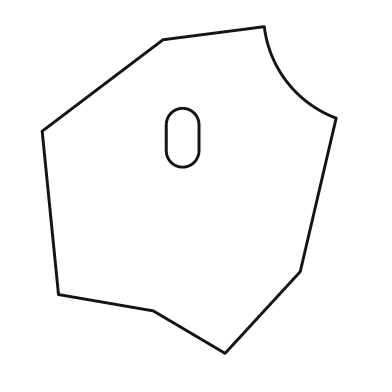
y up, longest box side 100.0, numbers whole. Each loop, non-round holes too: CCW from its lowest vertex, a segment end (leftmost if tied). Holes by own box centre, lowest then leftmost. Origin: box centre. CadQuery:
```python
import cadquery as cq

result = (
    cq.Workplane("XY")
    .moveTo(11.0, -50.0)
    .lineTo(34.0, -25.0)
    .lineTo(45.0, 22.0)
    .threePointArc((30.0, 33.0), (23.0, 50.0))
    .lineTo(-8.0, 46.0)
    .lineTo(-45.0, 18.0)
    .lineTo(-40.0, -32.0)
    .lineTo(-11.0, -37.0)
    .close()
    .moveTo(-7.0, 12.0)
    .threePointArc((-2.0, 7.0), (3.0, 12.0))
    .lineTo(3.0, 20.0)
    .threePointArc((-2.0, 25.0), (-7.0, 20.0))
    .close()
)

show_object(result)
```